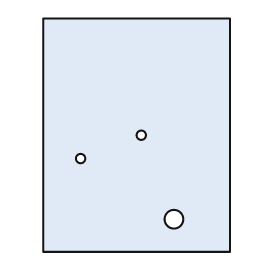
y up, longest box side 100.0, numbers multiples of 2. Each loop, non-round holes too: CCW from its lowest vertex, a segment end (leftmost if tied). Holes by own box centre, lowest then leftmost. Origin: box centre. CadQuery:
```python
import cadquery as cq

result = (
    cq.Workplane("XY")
    .moveTo(-40.0, -50.0)
    .lineTo(40.0, -50.0)
    .lineTo(40.0, 50.0)
    .lineTo(-40.0, 50.0)
    .close()
    .moveTo(16.0, -36.0)
    .circle(4.0)
    .moveTo(-24.0, -10.0)
    .circle(2.0)
    .moveTo(2.0, 0.0)
    .circle(2.0)
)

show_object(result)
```